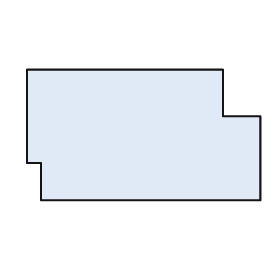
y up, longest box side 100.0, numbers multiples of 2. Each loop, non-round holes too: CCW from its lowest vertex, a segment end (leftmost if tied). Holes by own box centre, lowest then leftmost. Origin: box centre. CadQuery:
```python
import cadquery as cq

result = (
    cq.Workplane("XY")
    .moveTo(-44.0, -28.0)
    .lineTo(50.0, -28.0)
    .lineTo(50.0, 8.0)
    .lineTo(34.0, 8.0)
    .lineTo(34.0, 28.0)
    .lineTo(-50.0, 28.0)
    .lineTo(-50.0, -12.0)
    .lineTo(-44.0, -12.0)
    .close()
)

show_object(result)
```